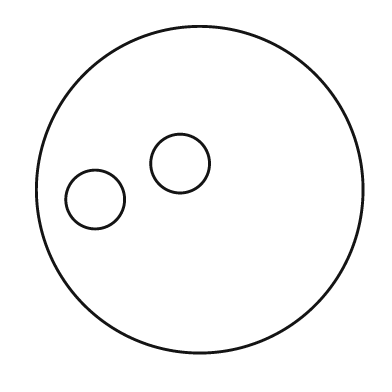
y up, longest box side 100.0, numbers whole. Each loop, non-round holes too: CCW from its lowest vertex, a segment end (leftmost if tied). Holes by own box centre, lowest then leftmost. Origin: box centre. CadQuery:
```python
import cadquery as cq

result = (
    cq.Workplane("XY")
    .moveTo(0.0, 0.0)
    .circle(50.0)
    .moveTo(-32.0, -3.0)
    .circle(9.0)
    .moveTo(-6.0, 8.0)
    .circle(9.0)
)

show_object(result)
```